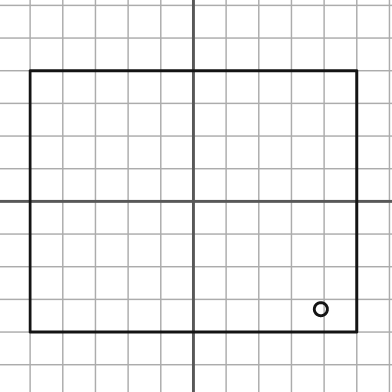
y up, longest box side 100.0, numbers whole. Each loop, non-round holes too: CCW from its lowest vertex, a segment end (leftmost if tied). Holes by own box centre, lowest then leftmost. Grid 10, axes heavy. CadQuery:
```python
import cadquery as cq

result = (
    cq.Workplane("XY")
    .moveTo(-50.0, -40.0)
    .lineTo(50.0, -40.0)
    .lineTo(50.0, 40.0)
    .lineTo(-50.0, 40.0)
    .close()
    .moveTo(39.0, -33.0)
    .circle(2.0)
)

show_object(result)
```